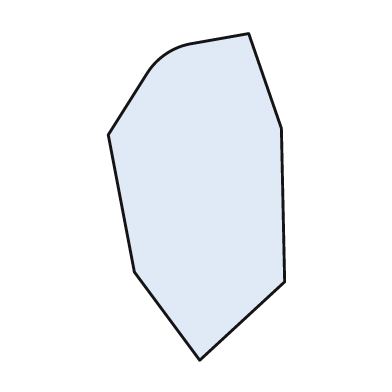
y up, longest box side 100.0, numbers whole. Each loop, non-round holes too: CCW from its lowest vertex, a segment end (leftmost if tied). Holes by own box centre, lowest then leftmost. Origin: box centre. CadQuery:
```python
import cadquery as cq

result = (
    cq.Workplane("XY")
    .moveTo(1.0, -50.0)
    .lineTo(27.0, -26.0)
    .lineTo(26.0, 21.0)
    .lineTo(16.0, 50.0)
    .lineTo(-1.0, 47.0)
    .threePointArc((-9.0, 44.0), (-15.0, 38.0))
    .lineTo(-27.0, 19.0)
    .lineTo(-19.0, -23.0)
    .close()
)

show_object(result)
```